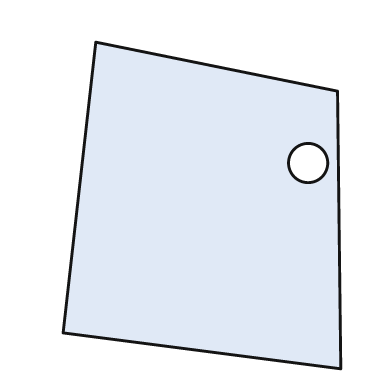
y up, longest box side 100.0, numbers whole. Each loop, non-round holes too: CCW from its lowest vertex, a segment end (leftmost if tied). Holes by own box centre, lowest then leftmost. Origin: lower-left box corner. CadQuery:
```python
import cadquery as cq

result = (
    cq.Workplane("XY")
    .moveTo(85.0, 0.0)
    .lineTo(84.0, 85.0)
    .lineTo(10.0, 100.0)
    .lineTo(0.0, 11.0)
    .close()
    .moveTo(75.0, 63.0)
    .circle(6.0)
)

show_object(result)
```